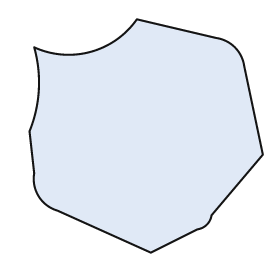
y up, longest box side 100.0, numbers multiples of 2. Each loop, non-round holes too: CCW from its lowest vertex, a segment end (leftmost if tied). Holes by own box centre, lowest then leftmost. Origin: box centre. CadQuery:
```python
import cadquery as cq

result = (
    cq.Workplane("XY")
    .moveTo(2.0, -50.0)
    .lineTo(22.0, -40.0)
    .threePointArc((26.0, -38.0), (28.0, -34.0))
    .lineTo(50.0, -8.0)
    .lineTo(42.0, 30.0)
    .threePointArc((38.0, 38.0), (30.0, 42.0))
    .lineTo(-4.0, 50.0)
    .threePointArc((-24.0, 36.0), (-48.0, 38.0))
    .threePointArc((-46.0, 20.0), (-50.0, 2.0))
    .lineTo(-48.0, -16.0)
    .threePointArc((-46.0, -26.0), (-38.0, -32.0))
    .close()
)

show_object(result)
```